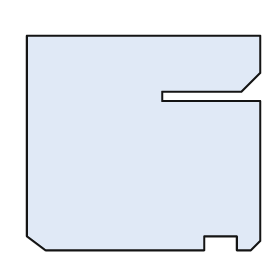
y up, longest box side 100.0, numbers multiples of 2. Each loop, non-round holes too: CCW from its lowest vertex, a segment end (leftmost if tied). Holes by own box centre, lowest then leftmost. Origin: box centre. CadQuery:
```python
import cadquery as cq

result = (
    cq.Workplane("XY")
    .moveTo(-42.0, -46.0)
    .lineTo(26.0, -46.0)
    .lineTo(26.0, -40.0)
    .lineTo(40.0, -40.0)
    .lineTo(40.0, -46.0)
    .lineTo(46.0, -46.0)
    .lineTo(50.0, -42.0)
    .lineTo(50.0, 18.0)
    .lineTo(8.0, 18.0)
    .lineTo(8.0, 22.0)
    .lineTo(42.0, 22.0)
    .lineTo(50.0, 30.0)
    .lineTo(50.0, 46.0)
    .lineTo(-50.0, 46.0)
    .lineTo(-50.0, -40.0)
    .close()
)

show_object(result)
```